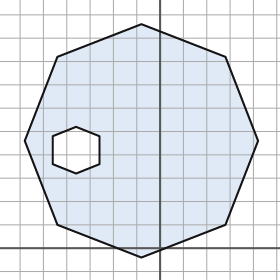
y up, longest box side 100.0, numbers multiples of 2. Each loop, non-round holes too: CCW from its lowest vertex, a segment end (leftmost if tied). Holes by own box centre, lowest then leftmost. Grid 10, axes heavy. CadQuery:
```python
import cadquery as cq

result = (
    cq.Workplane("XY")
    .moveTo(-8.0, -4.0)
    .lineTo(28.0, 10.0)
    .lineTo(42.0, 46.0)
    .lineTo(28.0, 82.0)
    .lineTo(-8.0, 96.0)
    .lineTo(-44.0, 82.0)
    .lineTo(-58.0, 46.0)
    .lineTo(-44.0, 10.0)
    .close()
    .moveTo(-36.0, 32.0)
    .lineTo(-26.0, 36.0)
    .lineTo(-26.0, 48.0)
    .lineTo(-36.0, 52.0)
    .lineTo(-46.0, 48.0)
    .lineTo(-46.0, 36.0)
    .close()
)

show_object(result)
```